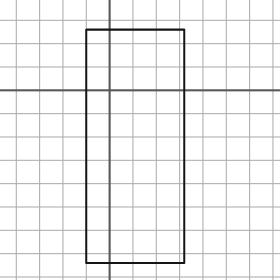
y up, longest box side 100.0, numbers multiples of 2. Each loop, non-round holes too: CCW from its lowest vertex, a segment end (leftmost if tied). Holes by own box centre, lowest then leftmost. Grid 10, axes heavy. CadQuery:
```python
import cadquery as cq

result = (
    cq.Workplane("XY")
    .moveTo(-10.0, -74.0)
    .lineTo(32.0, -74.0)
    .lineTo(32.0, 26.0)
    .lineTo(-10.0, 26.0)
    .close()
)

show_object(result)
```